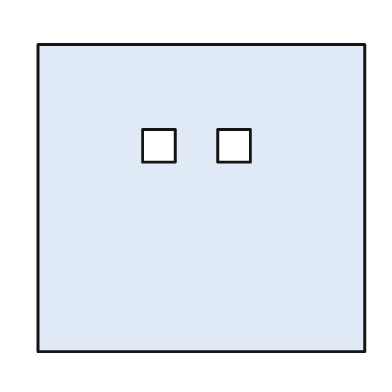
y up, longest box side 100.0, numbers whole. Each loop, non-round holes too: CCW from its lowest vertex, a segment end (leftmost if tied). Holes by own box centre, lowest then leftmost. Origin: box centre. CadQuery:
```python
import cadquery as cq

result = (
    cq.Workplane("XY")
    .moveTo(-50.0, -47.0)
    .lineTo(50.0, -47.0)
    .lineTo(50.0, 47.0)
    .lineTo(-50.0, 47.0)
    .close()
    .moveTo(-18.0, 11.0)
    .lineTo(-8.0, 11.0)
    .lineTo(-8.0, 21.0)
    .lineTo(-18.0, 21.0)
    .close()
    .moveTo(5.0, 11.0)
    .lineTo(15.0, 11.0)
    .lineTo(15.0, 21.0)
    .lineTo(5.0, 21.0)
    .close()
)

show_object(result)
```